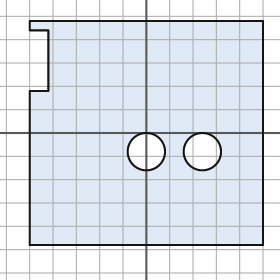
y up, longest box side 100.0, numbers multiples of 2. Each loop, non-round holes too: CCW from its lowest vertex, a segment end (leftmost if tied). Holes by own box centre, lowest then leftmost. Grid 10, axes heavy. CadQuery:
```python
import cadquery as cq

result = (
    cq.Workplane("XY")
    .moveTo(-50.0, -48.0)
    .lineTo(50.0, -48.0)
    .lineTo(50.0, 48.0)
    .lineTo(-50.0, 48.0)
    .lineTo(-50.0, 44.0)
    .lineTo(-42.0, 44.0)
    .lineTo(-42.0, 18.0)
    .lineTo(-50.0, 18.0)
    .close()
    .moveTo(0.0, -8.0)
    .circle(8.0)
    .moveTo(24.0, -8.0)
    .circle(8.0)
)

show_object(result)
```